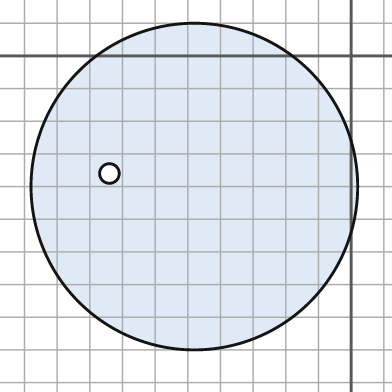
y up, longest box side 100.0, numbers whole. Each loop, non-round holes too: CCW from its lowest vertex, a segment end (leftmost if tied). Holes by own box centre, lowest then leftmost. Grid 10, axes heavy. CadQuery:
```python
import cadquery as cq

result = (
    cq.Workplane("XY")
    .moveTo(-48.0, -40.0)
    .circle(50.0)
    .moveTo(-74.0, -36.0)
    .circle(3.0)
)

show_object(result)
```